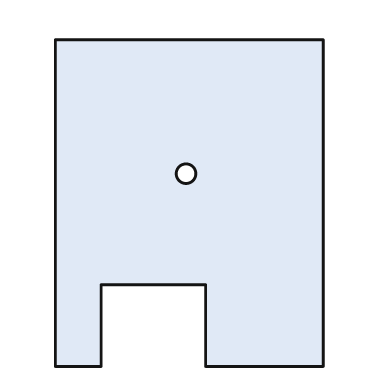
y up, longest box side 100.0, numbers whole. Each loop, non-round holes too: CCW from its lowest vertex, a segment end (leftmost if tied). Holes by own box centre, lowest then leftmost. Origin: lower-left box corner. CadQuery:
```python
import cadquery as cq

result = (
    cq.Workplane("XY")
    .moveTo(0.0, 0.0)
    .lineTo(14.0, 0.0)
    .lineTo(14.0, 25.0)
    .lineTo(46.0, 25.0)
    .lineTo(46.0, 0.0)
    .lineTo(82.0, 0.0)
    .lineTo(82.0, 100.0)
    .lineTo(0.0, 100.0)
    .close()
    .moveTo(40.0, 59.0)
    .circle(3.0)
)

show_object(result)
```